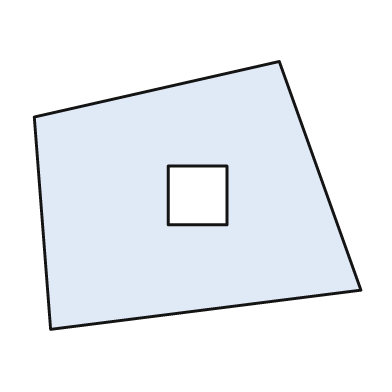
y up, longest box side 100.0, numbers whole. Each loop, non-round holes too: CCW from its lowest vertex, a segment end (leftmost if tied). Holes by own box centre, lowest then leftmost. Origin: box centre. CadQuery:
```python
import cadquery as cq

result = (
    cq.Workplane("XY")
    .moveTo(-45.0, -41.0)
    .lineTo(50.0, -29.0)
    .lineTo(25.0, 41.0)
    .lineTo(-50.0, 24.0)
    .close()
    .moveTo(-9.0, -9.0)
    .lineTo(9.0, -9.0)
    .lineTo(9.0, 9.0)
    .lineTo(-9.0, 9.0)
    .close()
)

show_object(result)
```